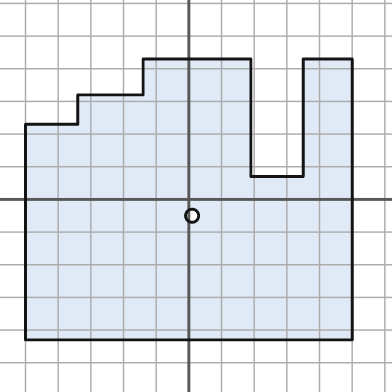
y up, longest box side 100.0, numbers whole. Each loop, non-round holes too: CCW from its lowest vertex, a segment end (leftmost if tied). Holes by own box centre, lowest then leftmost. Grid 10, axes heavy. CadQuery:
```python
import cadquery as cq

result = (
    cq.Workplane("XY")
    .moveTo(-50.0, -43.0)
    .lineTo(50.0, -43.0)
    .lineTo(50.0, 43.0)
    .lineTo(35.0, 43.0)
    .lineTo(35.0, 7.0)
    .lineTo(19.0, 7.0)
    .lineTo(19.0, 43.0)
    .lineTo(-14.0, 43.0)
    .lineTo(-14.0, 32.0)
    .lineTo(-34.0, 32.0)
    .lineTo(-34.0, 23.0)
    .lineTo(-50.0, 23.0)
    .close()
    .moveTo(1.0, -5.0)
    .circle(2.0)
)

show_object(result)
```